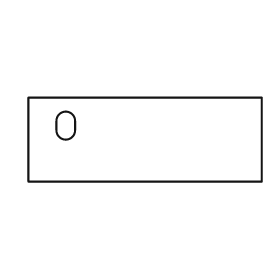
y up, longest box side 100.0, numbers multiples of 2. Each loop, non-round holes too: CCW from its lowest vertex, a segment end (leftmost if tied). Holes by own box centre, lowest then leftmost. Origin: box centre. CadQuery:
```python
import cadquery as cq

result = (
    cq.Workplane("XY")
    .moveTo(-50.0, -18.0)
    .lineTo(50.0, -18.0)
    .lineTo(50.0, 18.0)
    .lineTo(-50.0, 18.0)
    .close()
    .moveTo(-38.0, 4.0)
    .threePointArc((-34.0, 0.0), (-30.0, 4.0))
    .lineTo(-30.0, 8.0)
    .threePointArc((-34.0, 12.0), (-38.0, 8.0))
    .close()
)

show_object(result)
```